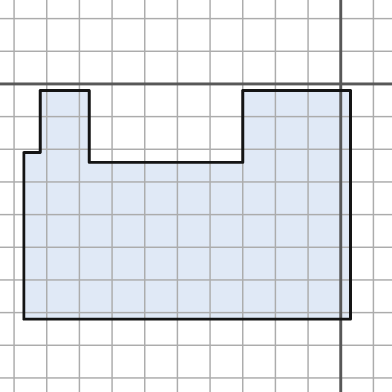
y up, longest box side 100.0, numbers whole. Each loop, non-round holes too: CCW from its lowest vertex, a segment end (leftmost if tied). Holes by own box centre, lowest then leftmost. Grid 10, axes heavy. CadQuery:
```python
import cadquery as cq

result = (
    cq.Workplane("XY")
    .moveTo(-97.0, -72.0)
    .lineTo(3.0, -72.0)
    .lineTo(3.0, -2.0)
    .lineTo(-30.0, -2.0)
    .lineTo(-30.0, -24.0)
    .lineTo(-77.0, -24.0)
    .lineTo(-77.0, -2.0)
    .lineTo(-92.0, -2.0)
    .lineTo(-92.0, -21.0)
    .lineTo(-97.0, -21.0)
    .close()
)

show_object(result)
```